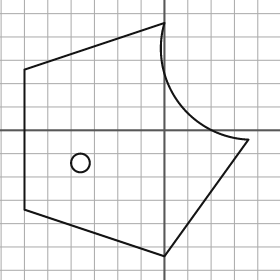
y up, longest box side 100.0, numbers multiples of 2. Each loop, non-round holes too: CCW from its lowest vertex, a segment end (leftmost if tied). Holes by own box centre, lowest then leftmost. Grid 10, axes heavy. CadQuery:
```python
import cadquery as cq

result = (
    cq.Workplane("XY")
    .moveTo(0.0, -54.0)
    .lineTo(36.0, -4.0)
    .threePointArc((6.0, 12.0), (0.0, 46.0))
    .lineTo(-60.0, 26.0)
    .lineTo(-60.0, -34.0)
    .close()
    .moveTo(-36.0, -14.0)
    .circle(4.0)
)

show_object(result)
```